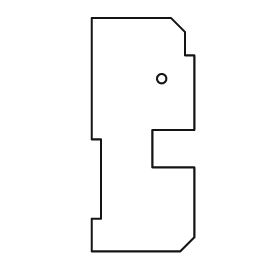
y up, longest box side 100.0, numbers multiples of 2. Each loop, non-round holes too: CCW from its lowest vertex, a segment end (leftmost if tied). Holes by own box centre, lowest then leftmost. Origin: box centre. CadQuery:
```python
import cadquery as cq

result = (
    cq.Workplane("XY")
    .moveTo(-22.0, -50.0)
    .lineTo(16.0, -50.0)
    .lineTo(22.0, -44.0)
    .lineTo(22.0, -14.0)
    .lineTo(4.0, -14.0)
    .lineTo(4.0, 2.0)
    .lineTo(22.0, 2.0)
    .lineTo(22.0, 34.0)
    .lineTo(18.0, 34.0)
    .lineTo(18.0, 44.0)
    .lineTo(12.0, 50.0)
    .lineTo(-22.0, 50.0)
    .lineTo(-22.0, -2.0)
    .lineTo(-18.0, -2.0)
    .lineTo(-18.0, -36.0)
    .lineTo(-22.0, -36.0)
    .close()
    .moveTo(8.0, 24.0)
    .circle(2.0)
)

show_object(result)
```